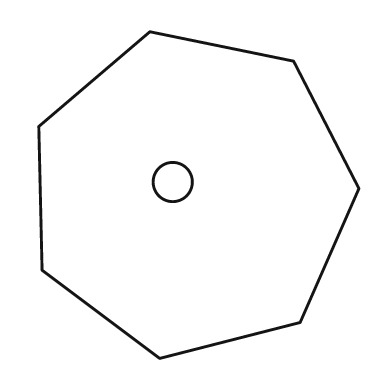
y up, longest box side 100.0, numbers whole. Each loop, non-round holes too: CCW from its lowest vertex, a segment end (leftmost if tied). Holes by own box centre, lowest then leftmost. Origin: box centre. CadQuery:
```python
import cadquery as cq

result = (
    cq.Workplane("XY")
    .moveTo(-12.0, -50.0)
    .lineTo(31.0, -39.0)
    .lineTo(49.0, 2.0)
    .lineTo(29.0, 41.0)
    .lineTo(-15.0, 50.0)
    .lineTo(-49.0, 21.0)
    .lineTo(-48.0, -23.0)
    .close()
    .moveTo(-8.0, 4.0)
    .circle(6.0)
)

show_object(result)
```